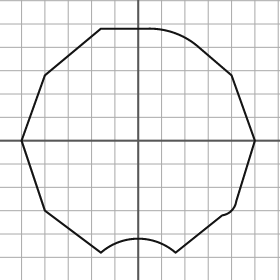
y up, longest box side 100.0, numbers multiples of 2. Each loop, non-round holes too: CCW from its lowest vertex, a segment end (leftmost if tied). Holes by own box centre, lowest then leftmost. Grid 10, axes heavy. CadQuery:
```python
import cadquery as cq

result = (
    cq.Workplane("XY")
    .moveTo(-16.0, -48.0)
    .threePointArc((0.0, -42.0), (16.0, -48.0))
    .lineTo(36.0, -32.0)
    .threePointArc((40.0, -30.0), (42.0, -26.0))
    .lineTo(50.0, 0.0)
    .lineTo(40.0, 28.0)
    .lineTo(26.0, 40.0)
    .threePointArc((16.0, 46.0), (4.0, 48.0))
    .lineTo(-16.0, 48.0)
    .lineTo(-40.0, 28.0)
    .lineTo(-50.0, 0.0)
    .lineTo(-40.0, -30.0)
    .close()
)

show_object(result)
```